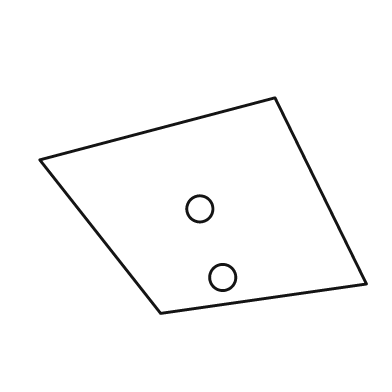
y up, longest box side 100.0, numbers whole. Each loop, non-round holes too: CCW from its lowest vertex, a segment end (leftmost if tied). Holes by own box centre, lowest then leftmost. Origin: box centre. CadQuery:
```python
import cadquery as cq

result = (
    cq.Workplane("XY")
    .moveTo(-13.0, -33.0)
    .lineTo(50.0, -24.0)
    .lineTo(22.0, 33.0)
    .lineTo(-50.0, 14.0)
    .close()
    .moveTo(6.0, -22.0)
    .circle(4.0)
    .moveTo(-1.0, -1.0)
    .circle(4.0)
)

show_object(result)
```